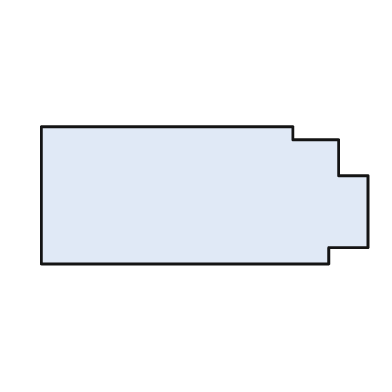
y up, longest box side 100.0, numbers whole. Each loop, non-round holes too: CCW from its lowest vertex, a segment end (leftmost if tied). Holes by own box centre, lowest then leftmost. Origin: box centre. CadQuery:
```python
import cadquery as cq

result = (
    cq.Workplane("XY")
    .moveTo(-50.0, -21.0)
    .lineTo(38.0, -21.0)
    .lineTo(38.0, -16.0)
    .lineTo(50.0, -16.0)
    .lineTo(50.0, 6.0)
    .lineTo(41.0, 6.0)
    .lineTo(41.0, 17.0)
    .lineTo(27.0, 17.0)
    .lineTo(27.0, 21.0)
    .lineTo(-50.0, 21.0)
    .close()
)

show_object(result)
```